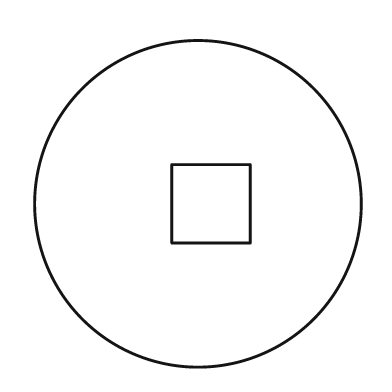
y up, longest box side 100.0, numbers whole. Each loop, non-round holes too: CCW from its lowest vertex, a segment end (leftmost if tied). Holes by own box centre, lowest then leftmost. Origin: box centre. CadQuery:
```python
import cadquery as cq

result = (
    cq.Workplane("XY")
    .moveTo(0.0, 0.0)
    .circle(50.0)
    .moveTo(-8.0, -12.0)
    .lineTo(16.0, -12.0)
    .lineTo(16.0, 12.0)
    .lineTo(-8.0, 12.0)
    .close()
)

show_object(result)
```